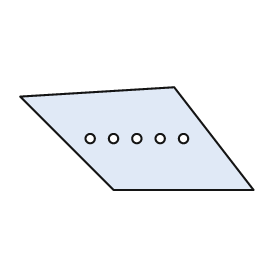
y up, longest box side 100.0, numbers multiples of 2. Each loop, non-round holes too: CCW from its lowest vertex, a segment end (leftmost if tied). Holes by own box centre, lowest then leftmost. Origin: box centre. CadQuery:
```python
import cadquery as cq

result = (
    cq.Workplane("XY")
    .moveTo(-10.0, -22.0)
    .lineTo(50.0, -22.0)
    .lineTo(16.0, 22.0)
    .lineTo(-50.0, 18.0)
    .close()
    .moveTo(-20.0, 0.0)
    .circle(2.0)
    .moveTo(-10.0, 0.0)
    .circle(2.0)
    .moveTo(0.0, 0.0)
    .circle(2.0)
    .moveTo(10.0, 0.0)
    .circle(2.0)
    .moveTo(20.0, 0.0)
    .circle(2.0)
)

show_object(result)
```